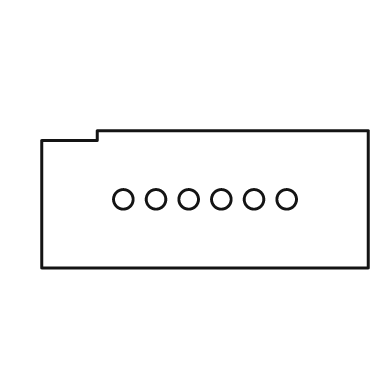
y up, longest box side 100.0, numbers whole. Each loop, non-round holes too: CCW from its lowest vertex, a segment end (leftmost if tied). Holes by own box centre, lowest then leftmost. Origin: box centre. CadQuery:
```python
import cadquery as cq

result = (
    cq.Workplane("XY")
    .moveTo(-50.0, -21.0)
    .lineTo(50.0, -21.0)
    .lineTo(50.0, 21.0)
    .lineTo(-33.0, 21.0)
    .lineTo(-33.0, 18.0)
    .lineTo(-50.0, 18.0)
    .close()
    .moveTo(-25.0, 0.0)
    .circle(3.0)
    .moveTo(-15.0, 0.0)
    .circle(3.0)
    .moveTo(-5.0, 0.0)
    .circle(3.0)
    .moveTo(5.0, 0.0)
    .circle(3.0)
    .moveTo(15.0, 0.0)
    .circle(3.0)
    .moveTo(25.0, 0.0)
    .circle(3.0)
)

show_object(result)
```